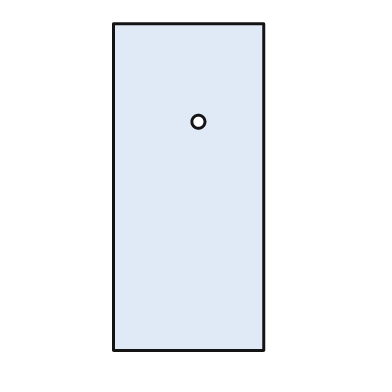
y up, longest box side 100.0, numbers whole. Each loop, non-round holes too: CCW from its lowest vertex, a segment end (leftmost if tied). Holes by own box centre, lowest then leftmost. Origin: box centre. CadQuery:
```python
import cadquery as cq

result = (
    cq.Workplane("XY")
    .moveTo(-23.0, -50.0)
    .lineTo(23.0, -50.0)
    .lineTo(23.0, 50.0)
    .lineTo(-23.0, 50.0)
    .close()
    .moveTo(3.0, 20.0)
    .circle(2.0)
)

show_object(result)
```